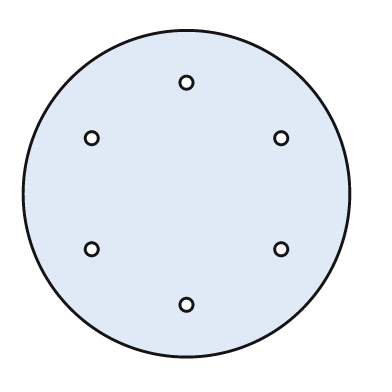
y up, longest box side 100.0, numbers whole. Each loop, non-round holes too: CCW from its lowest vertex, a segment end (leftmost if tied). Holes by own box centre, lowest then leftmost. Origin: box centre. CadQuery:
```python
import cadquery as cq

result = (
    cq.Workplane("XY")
    .moveTo(0.0, 0.0)
    .circle(50.0)
    .moveTo(0.0, -34.0)
    .circle(2.0)
    .moveTo(-29.0, -17.0)
    .circle(2.0)
    .moveTo(29.0, -17.0)
    .circle(2.0)
    .moveTo(-29.0, 17.0)
    .circle(2.0)
    .moveTo(29.0, 17.0)
    .circle(2.0)
    .moveTo(0.0, 34.0)
    .circle(2.0)
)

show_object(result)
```